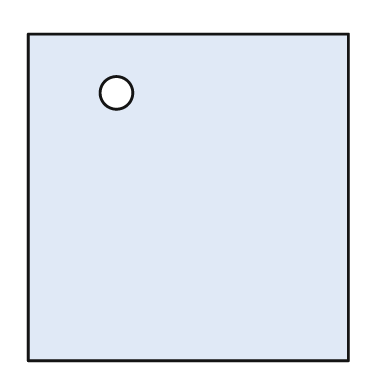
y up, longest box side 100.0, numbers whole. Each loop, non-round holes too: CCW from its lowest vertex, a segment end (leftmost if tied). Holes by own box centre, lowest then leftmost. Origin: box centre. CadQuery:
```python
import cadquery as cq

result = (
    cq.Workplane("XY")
    .moveTo(-49.0, -50.0)
    .lineTo(49.0, -50.0)
    .lineTo(49.0, 50.0)
    .lineTo(-49.0, 50.0)
    .close()
    .moveTo(-22.0, 32.0)
    .circle(5.0)
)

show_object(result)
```